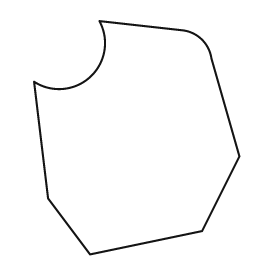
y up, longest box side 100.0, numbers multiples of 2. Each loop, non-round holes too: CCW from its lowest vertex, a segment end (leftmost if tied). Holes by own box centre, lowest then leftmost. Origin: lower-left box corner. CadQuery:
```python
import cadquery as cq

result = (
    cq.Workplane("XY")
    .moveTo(24.0, 0.0)
    .lineTo(72.0, 10.0)
    .lineTo(88.0, 42.0)
    .lineTo(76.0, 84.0)
    .threePointArc((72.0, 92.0), (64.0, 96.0))
    .lineTo(28.0, 100.0)
    .threePointArc((24.0, 76.0), (0.0, 74.0))
    .lineTo(6.0, 24.0)
    .close()
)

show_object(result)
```